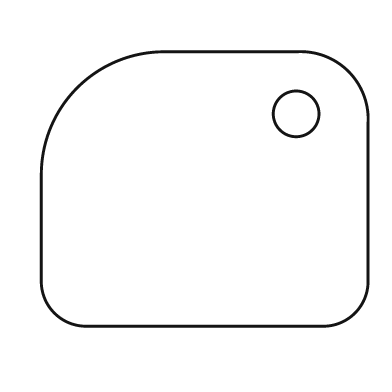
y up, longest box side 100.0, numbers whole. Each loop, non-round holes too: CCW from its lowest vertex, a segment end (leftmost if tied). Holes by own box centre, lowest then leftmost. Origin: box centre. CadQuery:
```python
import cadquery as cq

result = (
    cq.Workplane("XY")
    .moveTo(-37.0, -42.0)
    .lineTo(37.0, -42.0)
    .threePointArc((46.0, -38.0), (50.0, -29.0))
    .lineTo(50.0, 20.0)
    .threePointArc((44.0, 36.0), (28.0, 42.0))
    .lineTo(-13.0, 42.0)
    .threePointArc((-39.0, 31.0), (-50.0, 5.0))
    .lineTo(-50.0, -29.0)
    .threePointArc((-46.0, -38.0), (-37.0, -42.0))
    .close()
    .moveTo(28.0, 23.0)
    .circle(7.0)
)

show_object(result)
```